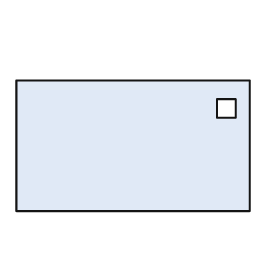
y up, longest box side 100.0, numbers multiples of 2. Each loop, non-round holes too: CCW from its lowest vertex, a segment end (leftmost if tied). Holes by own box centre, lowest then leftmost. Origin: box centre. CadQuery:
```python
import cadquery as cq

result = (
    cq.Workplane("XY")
    .moveTo(-50.0, -28.0)
    .lineTo(50.0, -28.0)
    .lineTo(50.0, 28.0)
    .lineTo(-50.0, 28.0)
    .close()
    .moveTo(36.0, 12.0)
    .lineTo(44.0, 12.0)
    .lineTo(44.0, 20.0)
    .lineTo(36.0, 20.0)
    .close()
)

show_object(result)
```